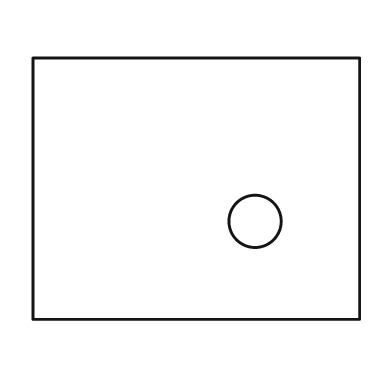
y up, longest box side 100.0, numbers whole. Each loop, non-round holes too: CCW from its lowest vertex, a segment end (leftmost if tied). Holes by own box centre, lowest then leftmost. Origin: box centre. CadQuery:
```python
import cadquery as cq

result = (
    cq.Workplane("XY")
    .moveTo(-50.0, -40.0)
    .lineTo(50.0, -40.0)
    .lineTo(50.0, 40.0)
    .lineTo(-50.0, 40.0)
    .close()
    .moveTo(18.0, -10.0)
    .circle(8.0)
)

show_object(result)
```